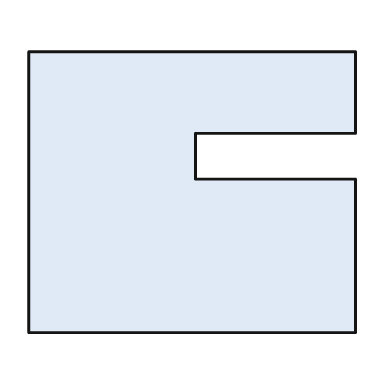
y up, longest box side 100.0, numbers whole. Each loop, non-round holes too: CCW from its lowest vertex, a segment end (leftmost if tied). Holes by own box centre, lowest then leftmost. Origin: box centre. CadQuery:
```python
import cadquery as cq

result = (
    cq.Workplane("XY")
    .moveTo(-50.0, -43.0)
    .lineTo(50.0, -43.0)
    .lineTo(50.0, 4.0)
    .lineTo(1.0, 4.0)
    .lineTo(1.0, 18.0)
    .lineTo(50.0, 18.0)
    .lineTo(50.0, 43.0)
    .lineTo(-50.0, 43.0)
    .close()
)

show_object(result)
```